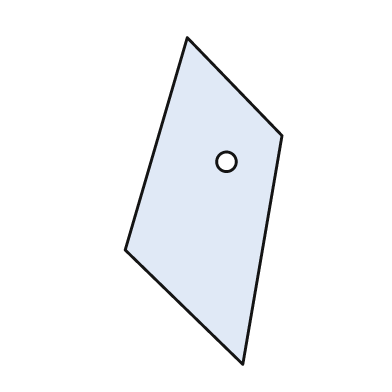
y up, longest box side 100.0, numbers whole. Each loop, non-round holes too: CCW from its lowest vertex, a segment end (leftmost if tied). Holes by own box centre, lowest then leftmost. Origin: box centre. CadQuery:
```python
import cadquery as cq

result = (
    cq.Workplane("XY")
    .moveTo(12.0, -50.0)
    .lineTo(24.0, 20.0)
    .lineTo(-5.0, 50.0)
    .lineTo(-24.0, -15.0)
    .close()
    .moveTo(7.0, 12.0)
    .circle(3.0)
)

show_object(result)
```